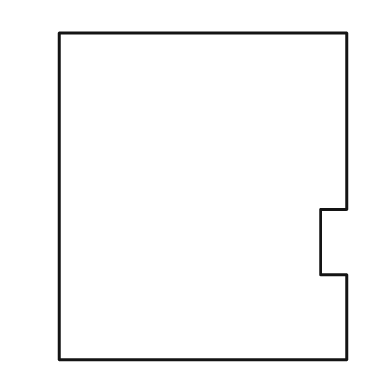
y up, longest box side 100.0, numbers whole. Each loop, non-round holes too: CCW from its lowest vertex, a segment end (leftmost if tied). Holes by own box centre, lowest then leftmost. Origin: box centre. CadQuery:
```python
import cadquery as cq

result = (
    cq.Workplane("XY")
    .moveTo(-44.0, -50.0)
    .lineTo(44.0, -50.0)
    .lineTo(44.0, -24.0)
    .lineTo(36.0, -24.0)
    .lineTo(36.0, -4.0)
    .lineTo(44.0, -4.0)
    .lineTo(44.0, 50.0)
    .lineTo(-44.0, 50.0)
    .close()
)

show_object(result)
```